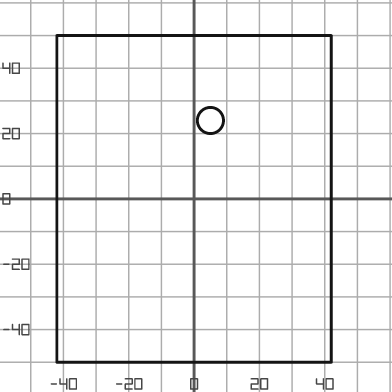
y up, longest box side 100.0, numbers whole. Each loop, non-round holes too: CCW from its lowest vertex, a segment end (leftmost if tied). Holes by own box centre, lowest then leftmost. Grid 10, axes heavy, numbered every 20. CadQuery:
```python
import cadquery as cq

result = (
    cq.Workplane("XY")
    .moveTo(-42.0, -50.0)
    .lineTo(42.0, -50.0)
    .lineTo(42.0, 50.0)
    .lineTo(-42.0, 50.0)
    .close()
    .moveTo(5.0, 24.0)
    .circle(4.0)
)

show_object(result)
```